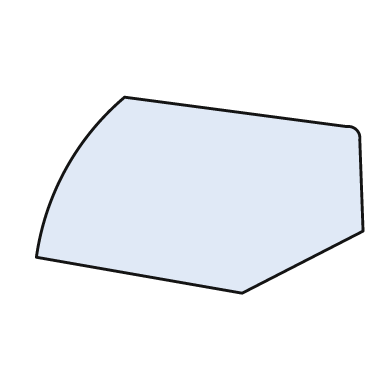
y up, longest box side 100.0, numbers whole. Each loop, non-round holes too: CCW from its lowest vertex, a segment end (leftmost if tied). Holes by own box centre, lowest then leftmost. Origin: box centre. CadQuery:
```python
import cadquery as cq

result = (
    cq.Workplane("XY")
    .moveTo(13.0, -30.0)
    .lineTo(50.0, -11.0)
    .lineTo(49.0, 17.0)
    .threePointArc((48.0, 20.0), (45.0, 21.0))
    .lineTo(-23.0, 30.0)
    .threePointArc((-41.0, 8.0), (-50.0, -19.0))
    .close()
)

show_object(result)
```